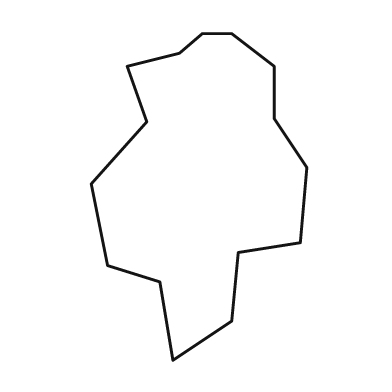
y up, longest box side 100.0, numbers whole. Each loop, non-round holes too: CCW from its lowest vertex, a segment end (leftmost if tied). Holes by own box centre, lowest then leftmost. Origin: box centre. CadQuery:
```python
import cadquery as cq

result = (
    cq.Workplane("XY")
    .moveTo(-8.0, -50.0)
    .lineTo(10.0, -38.0)
    .lineTo(12.0, -17.0)
    .lineTo(31.0, -14.0)
    .lineTo(33.0, 9.0)
    .lineTo(23.0, 24.0)
    .lineTo(23.0, 40.0)
    .lineTo(10.0, 50.0)
    .lineTo(1.0, 50.0)
    .lineTo(-6.0, 44.0)
    .lineTo(-22.0, 40.0)
    .lineTo(-16.0, 23.0)
    .lineTo(-33.0, 4.0)
    .lineTo(-28.0, -21.0)
    .lineTo(-12.0, -26.0)
    .close()
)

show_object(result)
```